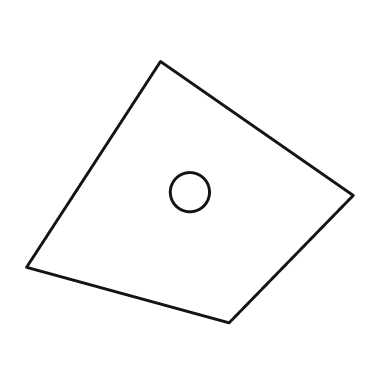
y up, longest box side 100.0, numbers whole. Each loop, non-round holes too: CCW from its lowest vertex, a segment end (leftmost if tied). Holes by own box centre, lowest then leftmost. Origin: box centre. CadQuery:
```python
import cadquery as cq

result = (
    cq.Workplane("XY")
    .moveTo(12.0, -40.0)
    .lineTo(50.0, -1.0)
    .lineTo(-9.0, 40.0)
    .lineTo(-50.0, -23.0)
    .close()
    .moveTo(0.0, 0.0)
    .circle(6.0)
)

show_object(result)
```